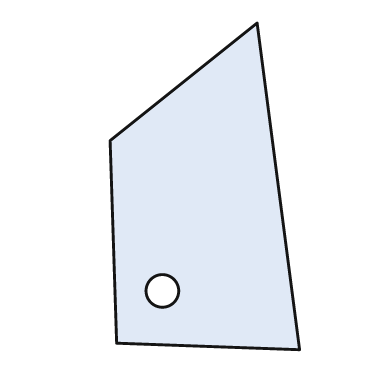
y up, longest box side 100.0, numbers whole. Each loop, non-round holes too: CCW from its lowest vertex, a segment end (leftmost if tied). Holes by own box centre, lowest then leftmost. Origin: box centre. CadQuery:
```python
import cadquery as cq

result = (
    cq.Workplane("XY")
    .moveTo(29.0, -50.0)
    .lineTo(16.0, 50.0)
    .lineTo(-29.0, 14.0)
    .lineTo(-27.0, -48.0)
    .close()
    .moveTo(-13.0, -32.0)
    .circle(5.0)
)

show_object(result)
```